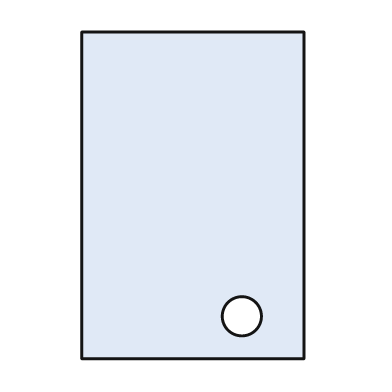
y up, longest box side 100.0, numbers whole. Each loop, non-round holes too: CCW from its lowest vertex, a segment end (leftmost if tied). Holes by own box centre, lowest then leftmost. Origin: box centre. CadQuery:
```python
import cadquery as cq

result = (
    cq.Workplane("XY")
    .moveTo(-34.0, -50.0)
    .lineTo(34.0, -50.0)
    .lineTo(34.0, 50.0)
    .lineTo(-34.0, 50.0)
    .close()
    .moveTo(15.0, -37.0)
    .circle(6.0)
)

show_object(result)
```